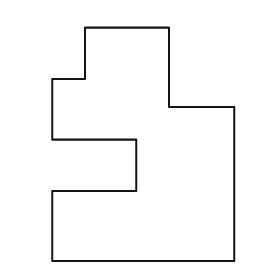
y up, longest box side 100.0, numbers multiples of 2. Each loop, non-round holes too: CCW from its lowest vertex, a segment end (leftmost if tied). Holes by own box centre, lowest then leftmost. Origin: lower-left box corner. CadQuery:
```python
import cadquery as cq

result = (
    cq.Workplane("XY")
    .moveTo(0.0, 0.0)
    .lineTo(78.0, 0.0)
    .lineTo(78.0, 66.0)
    .lineTo(50.0, 66.0)
    .lineTo(50.0, 100.0)
    .lineTo(14.0, 100.0)
    .lineTo(14.0, 78.0)
    .lineTo(0.0, 78.0)
    .lineTo(0.0, 52.0)
    .lineTo(36.0, 52.0)
    .lineTo(36.0, 30.0)
    .lineTo(0.0, 30.0)
    .close()
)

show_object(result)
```